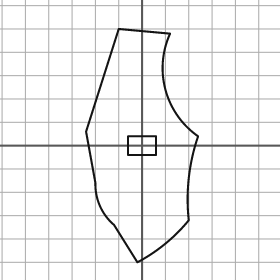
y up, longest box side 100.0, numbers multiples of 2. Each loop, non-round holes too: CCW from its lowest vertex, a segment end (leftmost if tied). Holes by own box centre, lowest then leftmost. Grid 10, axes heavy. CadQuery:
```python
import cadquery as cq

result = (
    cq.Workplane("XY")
    .moveTo(-2.0, -50.0)
    .threePointArc((10.0, -42.0), (20.0, -32.0))
    .threePointArc((20.0, -14.0), (24.0, 4.0))
    .threePointArc((10.0, 24.0), (12.0, 48.0))
    .lineTo(-10.0, 50.0)
    .lineTo(-24.0, 6.0)
    .lineTo(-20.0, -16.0)
    .threePointArc((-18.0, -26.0), (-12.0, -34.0))
    .close()
    .moveTo(-6.0, -4.0)
    .lineTo(6.0, -4.0)
    .lineTo(6.0, 4.0)
    .lineTo(-6.0, 4.0)
    .close()
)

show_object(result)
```